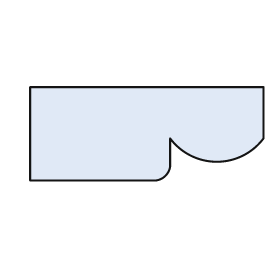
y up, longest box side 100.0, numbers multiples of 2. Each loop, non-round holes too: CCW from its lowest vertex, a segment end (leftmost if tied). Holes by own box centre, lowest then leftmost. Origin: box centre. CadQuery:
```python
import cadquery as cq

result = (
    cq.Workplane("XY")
    .moveTo(-50.0, -20.0)
    .lineTo(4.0, -20.0)
    .threePointArc((8.0, -18.0), (10.0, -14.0))
    .lineTo(10.0, -2.0)
    .threePointArc((30.0, -12.0), (50.0, -2.0))
    .lineTo(50.0, 20.0)
    .lineTo(-50.0, 20.0)
    .close()
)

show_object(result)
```